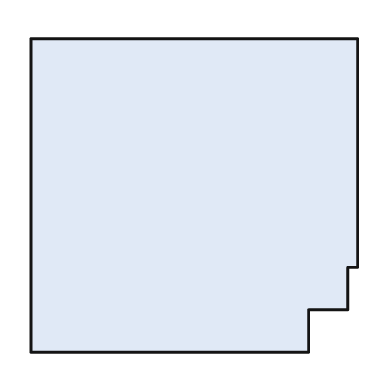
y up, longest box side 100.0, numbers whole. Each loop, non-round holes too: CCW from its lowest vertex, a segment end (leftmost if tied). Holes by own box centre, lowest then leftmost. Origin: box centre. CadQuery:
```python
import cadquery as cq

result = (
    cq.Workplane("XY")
    .moveTo(-50.0, -48.0)
    .lineTo(35.0, -48.0)
    .lineTo(35.0, -35.0)
    .lineTo(47.0, -35.0)
    .lineTo(47.0, -22.0)
    .lineTo(50.0, -22.0)
    .lineTo(50.0, 48.0)
    .lineTo(-50.0, 48.0)
    .close()
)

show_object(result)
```